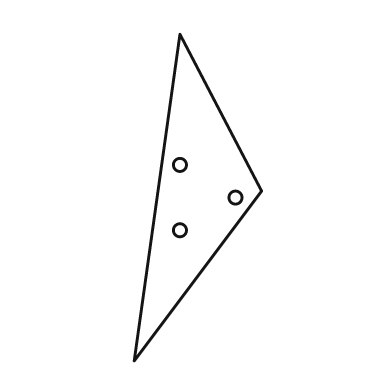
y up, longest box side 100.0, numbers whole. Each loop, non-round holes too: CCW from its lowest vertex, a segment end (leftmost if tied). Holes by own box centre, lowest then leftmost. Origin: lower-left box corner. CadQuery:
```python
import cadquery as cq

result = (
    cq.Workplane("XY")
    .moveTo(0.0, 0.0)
    .lineTo(39.0, 52.0)
    .lineTo(14.0, 100.0)
    .close()
    .moveTo(14.0, 40.0)
    .circle(2.0)
    .moveTo(31.0, 50.0)
    .circle(2.0)
    .moveTo(14.0, 60.0)
    .circle(2.0)
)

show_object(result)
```